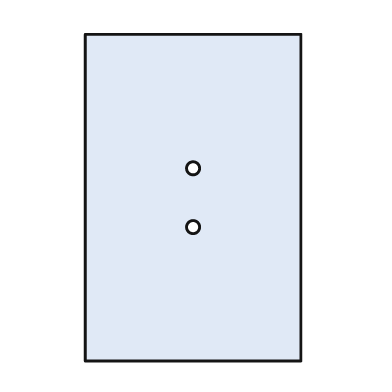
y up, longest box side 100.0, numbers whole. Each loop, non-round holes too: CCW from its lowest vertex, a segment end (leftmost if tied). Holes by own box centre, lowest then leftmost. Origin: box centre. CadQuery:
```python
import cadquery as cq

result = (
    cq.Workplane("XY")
    .moveTo(-33.0, -50.0)
    .lineTo(33.0, -50.0)
    .lineTo(33.0, 50.0)
    .lineTo(-33.0, 50.0)
    .close()
    .moveTo(0.0, -9.0)
    .circle(2.0)
    .moveTo(0.0, 9.0)
    .circle(2.0)
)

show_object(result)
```